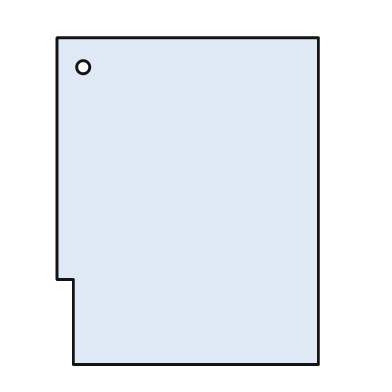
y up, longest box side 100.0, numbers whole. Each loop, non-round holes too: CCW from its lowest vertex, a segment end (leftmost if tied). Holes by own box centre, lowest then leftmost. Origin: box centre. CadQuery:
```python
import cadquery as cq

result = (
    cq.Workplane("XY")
    .moveTo(-35.0, -50.0)
    .lineTo(40.0, -50.0)
    .lineTo(40.0, 50.0)
    .lineTo(-40.0, 50.0)
    .lineTo(-40.0, -24.0)
    .lineTo(-35.0, -24.0)
    .close()
    .moveTo(-32.0, 41.0)
    .circle(2.0)
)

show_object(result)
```